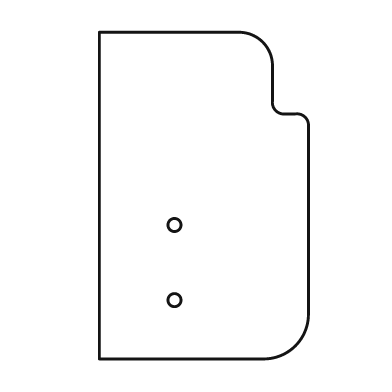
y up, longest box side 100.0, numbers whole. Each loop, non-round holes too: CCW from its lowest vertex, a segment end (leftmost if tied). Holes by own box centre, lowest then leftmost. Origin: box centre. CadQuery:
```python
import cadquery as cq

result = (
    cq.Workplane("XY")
    .moveTo(-32.0, -50.0)
    .lineTo(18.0, -50.0)
    .threePointArc((28.0, -46.0), (32.0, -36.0))
    .lineTo(32.0, 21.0)
    .threePointArc((31.0, 24.0), (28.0, 25.0))
    .lineTo(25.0, 25.0)
    .threePointArc((22.0, 26.0), (21.0, 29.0))
    .lineTo(21.0, 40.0)
    .threePointArc((18.0, 47.0), (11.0, 50.0))
    .lineTo(-32.0, 50.0)
    .close()
    .moveTo(-9.0, -32.0)
    .circle(2.0)
    .moveTo(-9.0, -9.0)
    .circle(2.0)
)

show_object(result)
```